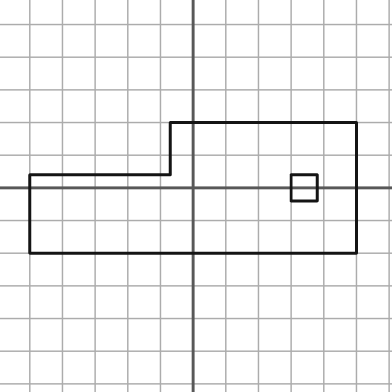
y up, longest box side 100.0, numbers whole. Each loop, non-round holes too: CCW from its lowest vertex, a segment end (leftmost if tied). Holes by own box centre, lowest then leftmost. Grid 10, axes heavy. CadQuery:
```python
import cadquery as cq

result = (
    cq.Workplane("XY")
    .moveTo(-50.0, -20.0)
    .lineTo(50.0, -20.0)
    .lineTo(50.0, 20.0)
    .lineTo(-7.0, 20.0)
    .lineTo(-7.0, 4.0)
    .lineTo(-50.0, 4.0)
    .close()
    .moveTo(30.0, -4.0)
    .lineTo(38.0, -4.0)
    .lineTo(38.0, 4.0)
    .lineTo(30.0, 4.0)
    .close()
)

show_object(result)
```